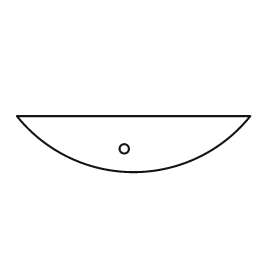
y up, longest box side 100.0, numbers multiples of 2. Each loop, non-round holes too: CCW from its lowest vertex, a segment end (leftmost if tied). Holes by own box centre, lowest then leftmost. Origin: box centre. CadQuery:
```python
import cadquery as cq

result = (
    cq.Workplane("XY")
    .moveTo(-50.0, 12.0)
    .threePointArc((0.0, -12.0), (50.0, 12.0))
    .close()
    .moveTo(-4.0, -2.0)
    .circle(2.0)
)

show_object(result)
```